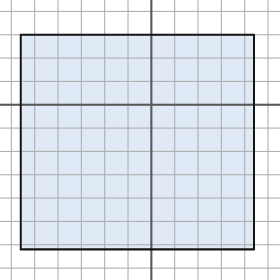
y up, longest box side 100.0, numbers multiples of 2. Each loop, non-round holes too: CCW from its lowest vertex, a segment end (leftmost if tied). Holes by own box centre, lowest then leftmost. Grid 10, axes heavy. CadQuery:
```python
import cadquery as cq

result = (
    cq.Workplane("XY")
    .moveTo(-56.0, -62.0)
    .lineTo(44.0, -62.0)
    .lineTo(44.0, 30.0)
    .lineTo(-56.0, 30.0)
    .close()
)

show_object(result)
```